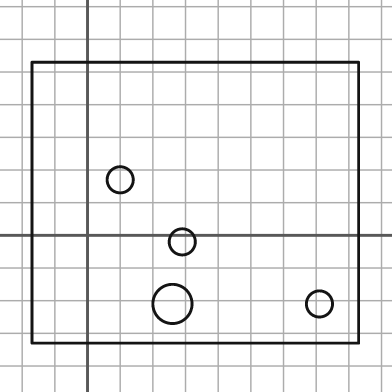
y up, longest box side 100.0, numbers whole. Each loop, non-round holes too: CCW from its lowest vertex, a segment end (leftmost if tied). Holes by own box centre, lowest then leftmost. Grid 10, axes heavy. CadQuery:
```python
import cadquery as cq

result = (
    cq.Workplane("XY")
    .moveTo(-17.0, -33.0)
    .lineTo(83.0, -33.0)
    .lineTo(83.0, 53.0)
    .lineTo(-17.0, 53.0)
    .close()
    .moveTo(26.0, -21.0)
    .circle(6.0)
    .moveTo(71.0, -21.0)
    .circle(4.0)
    .moveTo(29.0, -2.0)
    .circle(4.0)
    .moveTo(10.0, 17.0)
    .circle(4.0)
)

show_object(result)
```